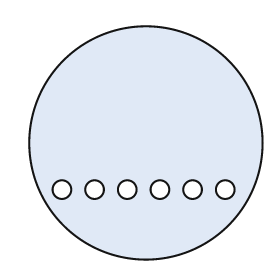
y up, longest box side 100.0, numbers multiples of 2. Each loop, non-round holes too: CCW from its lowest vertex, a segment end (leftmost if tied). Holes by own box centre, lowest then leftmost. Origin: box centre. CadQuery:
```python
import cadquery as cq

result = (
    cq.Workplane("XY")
    .moveTo(0.0, 0.0)
    .circle(50.0)
    .moveTo(-36.0, -20.0)
    .circle(4.0)
    .moveTo(-22.0, -20.0)
    .circle(4.0)
    .moveTo(-8.0, -20.0)
    .circle(4.0)
    .moveTo(6.0, -20.0)
    .circle(4.0)
    .moveTo(20.0, -20.0)
    .circle(4.0)
    .moveTo(34.0, -20.0)
    .circle(4.0)
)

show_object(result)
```